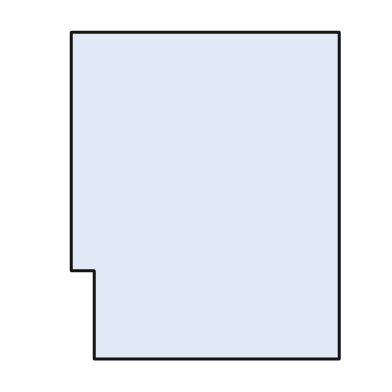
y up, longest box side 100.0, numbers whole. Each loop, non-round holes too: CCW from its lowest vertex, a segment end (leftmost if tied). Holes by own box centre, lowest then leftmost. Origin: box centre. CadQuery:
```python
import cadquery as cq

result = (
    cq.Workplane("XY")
    .moveTo(-34.0, -50.0)
    .lineTo(41.0, -50.0)
    .lineTo(41.0, 50.0)
    .lineTo(-41.0, 50.0)
    .lineTo(-41.0, -23.0)
    .lineTo(-34.0, -23.0)
    .close()
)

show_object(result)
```